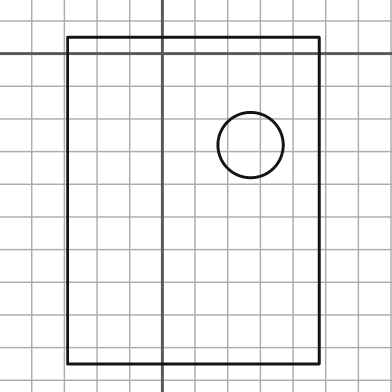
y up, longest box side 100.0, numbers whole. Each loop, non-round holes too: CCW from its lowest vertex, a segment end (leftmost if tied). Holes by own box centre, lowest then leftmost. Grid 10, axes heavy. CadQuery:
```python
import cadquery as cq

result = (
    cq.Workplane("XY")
    .moveTo(-29.0, -95.0)
    .lineTo(48.0, -95.0)
    .lineTo(48.0, 5.0)
    .lineTo(-29.0, 5.0)
    .close()
    .moveTo(27.0, -28.0)
    .circle(10.0)
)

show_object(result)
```